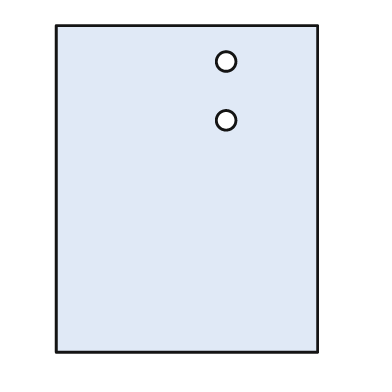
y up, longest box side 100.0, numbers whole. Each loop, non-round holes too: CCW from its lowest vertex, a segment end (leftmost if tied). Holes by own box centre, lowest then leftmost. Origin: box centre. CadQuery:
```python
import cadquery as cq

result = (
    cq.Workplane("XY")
    .moveTo(-40.0, -50.0)
    .lineTo(40.0, -50.0)
    .lineTo(40.0, 50.0)
    .lineTo(-40.0, 50.0)
    .close()
    .moveTo(12.0, 21.0)
    .circle(3.0)
    .moveTo(12.0, 39.0)
    .circle(3.0)
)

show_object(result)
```